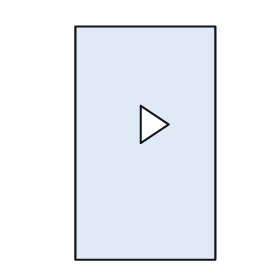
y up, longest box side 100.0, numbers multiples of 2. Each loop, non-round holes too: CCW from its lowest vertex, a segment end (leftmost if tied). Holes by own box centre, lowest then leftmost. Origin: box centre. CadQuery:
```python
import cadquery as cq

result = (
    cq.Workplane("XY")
    .moveTo(-30.0, -50.0)
    .lineTo(30.0, -50.0)
    .lineTo(30.0, 50.0)
    .lineTo(-30.0, 50.0)
    .close()
    .moveTo(-2.0, 0.0)
    .lineTo(10.0, 8.0)
    .lineTo(-2.0, 16.0)
    .close()
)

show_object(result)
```